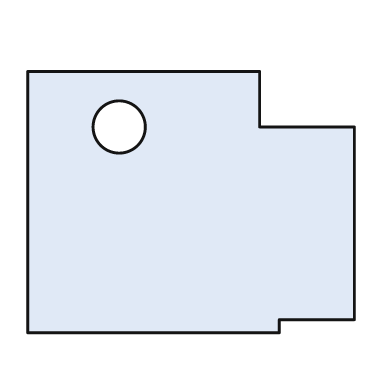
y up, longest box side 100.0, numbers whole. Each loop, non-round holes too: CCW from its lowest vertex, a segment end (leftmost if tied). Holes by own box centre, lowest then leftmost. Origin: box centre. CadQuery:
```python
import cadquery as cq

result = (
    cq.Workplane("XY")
    .moveTo(-50.0, -40.0)
    .lineTo(27.0, -40.0)
    .lineTo(27.0, -36.0)
    .lineTo(50.0, -36.0)
    .lineTo(50.0, 23.0)
    .lineTo(21.0, 23.0)
    .lineTo(21.0, 40.0)
    .lineTo(-50.0, 40.0)
    .close()
    .moveTo(-22.0, 23.0)
    .circle(8.0)
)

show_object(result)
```